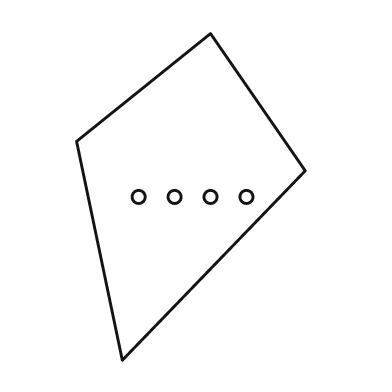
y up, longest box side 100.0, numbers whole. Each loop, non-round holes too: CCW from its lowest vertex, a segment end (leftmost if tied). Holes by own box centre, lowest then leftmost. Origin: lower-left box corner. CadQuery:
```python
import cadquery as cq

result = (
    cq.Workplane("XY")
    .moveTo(14.0, 0.0)
    .lineTo(70.0, 58.0)
    .lineTo(41.0, 100.0)
    .lineTo(0.0, 67.0)
    .close()
    .moveTo(19.0, 50.0)
    .circle(2.0)
    .moveTo(30.0, 50.0)
    .circle(2.0)
    .moveTo(41.0, 50.0)
    .circle(2.0)
    .moveTo(52.0, 50.0)
    .circle(2.0)
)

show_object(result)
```